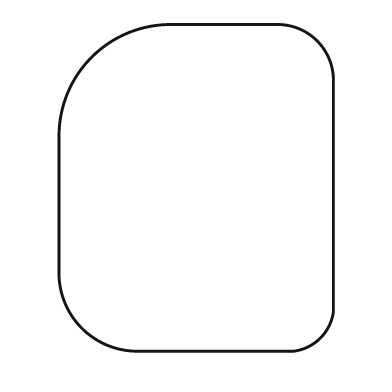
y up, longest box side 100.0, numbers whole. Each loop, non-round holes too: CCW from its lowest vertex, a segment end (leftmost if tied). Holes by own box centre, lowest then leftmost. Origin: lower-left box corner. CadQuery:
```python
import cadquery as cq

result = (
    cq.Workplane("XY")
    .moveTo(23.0, 0.0)
    .lineTo(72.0, 0.0)
    .threePointArc((80.0, 4.0), (84.0, 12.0))
    .lineTo(84.0, 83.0)
    .threePointArc((79.0, 95.0), (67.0, 100.0))
    .lineTo(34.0, 100.0)
    .threePointArc((10.0, 90.0), (0.0, 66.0))
    .lineTo(0.0, 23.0)
    .threePointArc((7.0, 7.0), (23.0, 0.0))
    .close()
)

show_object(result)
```